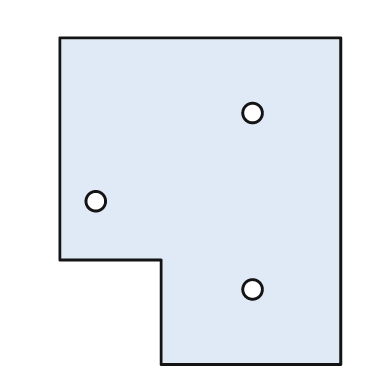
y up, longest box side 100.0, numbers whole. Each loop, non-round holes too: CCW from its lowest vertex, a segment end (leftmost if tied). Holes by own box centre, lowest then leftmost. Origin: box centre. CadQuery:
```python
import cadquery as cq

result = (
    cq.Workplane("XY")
    .moveTo(-12.0, -50.0)
    .lineTo(43.0, -50.0)
    .lineTo(43.0, 50.0)
    .lineTo(-43.0, 50.0)
    .lineTo(-43.0, -18.0)
    .lineTo(-12.0, -18.0)
    .close()
    .moveTo(16.0, -27.0)
    .circle(3.0)
    .moveTo(-32.0, 0.0)
    .circle(3.0)
    .moveTo(16.0, 27.0)
    .circle(3.0)
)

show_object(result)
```